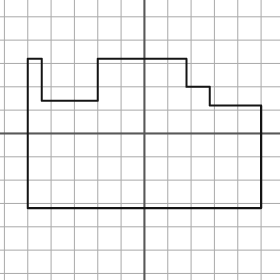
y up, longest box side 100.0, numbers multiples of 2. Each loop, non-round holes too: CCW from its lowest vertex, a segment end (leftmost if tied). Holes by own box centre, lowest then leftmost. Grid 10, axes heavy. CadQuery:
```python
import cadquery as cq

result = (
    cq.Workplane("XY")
    .moveTo(-50.0, -32.0)
    .lineTo(50.0, -32.0)
    .lineTo(50.0, 12.0)
    .lineTo(28.0, 12.0)
    .lineTo(28.0, 20.0)
    .lineTo(18.0, 20.0)
    .lineTo(18.0, 32.0)
    .lineTo(-20.0, 32.0)
    .lineTo(-20.0, 14.0)
    .lineTo(-44.0, 14.0)
    .lineTo(-44.0, 32.0)
    .lineTo(-50.0, 32.0)
    .close()
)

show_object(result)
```